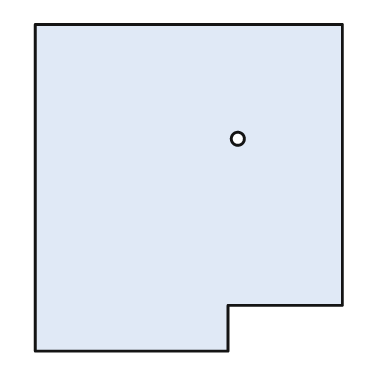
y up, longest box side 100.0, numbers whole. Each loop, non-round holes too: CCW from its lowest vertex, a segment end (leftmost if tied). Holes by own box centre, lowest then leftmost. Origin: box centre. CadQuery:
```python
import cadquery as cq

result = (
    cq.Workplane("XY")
    .moveTo(-47.0, -50.0)
    .lineTo(12.0, -50.0)
    .lineTo(12.0, -36.0)
    .lineTo(47.0, -36.0)
    .lineTo(47.0, 50.0)
    .lineTo(-47.0, 50.0)
    .close()
    .moveTo(15.0, 15.0)
    .circle(2.0)
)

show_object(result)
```